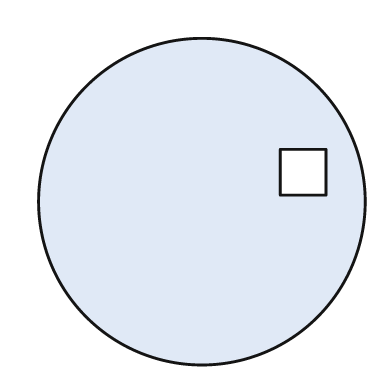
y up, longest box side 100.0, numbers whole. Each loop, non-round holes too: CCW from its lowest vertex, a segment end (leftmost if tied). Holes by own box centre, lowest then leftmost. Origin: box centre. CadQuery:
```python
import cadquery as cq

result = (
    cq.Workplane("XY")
    .moveTo(0.0, 0.0)
    .circle(50.0)
    .moveTo(24.0, 2.0)
    .lineTo(38.0, 2.0)
    .lineTo(38.0, 16.0)
    .lineTo(24.0, 16.0)
    .close()
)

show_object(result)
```